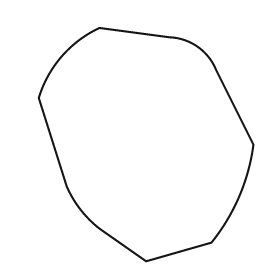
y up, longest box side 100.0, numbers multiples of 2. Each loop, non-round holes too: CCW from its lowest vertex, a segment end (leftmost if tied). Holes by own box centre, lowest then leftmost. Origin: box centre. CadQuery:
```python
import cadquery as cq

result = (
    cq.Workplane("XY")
    .moveTo(0.0, -50.0)
    .lineTo(28.0, -42.0)
    .threePointArc((40.0, -22.0), (46.0, 0.0))
    .lineTo(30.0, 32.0)
    .threePointArc((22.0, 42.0), (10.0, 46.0))
    .lineTo(-20.0, 50.0)
    .threePointArc((-36.0, 38.0), (-46.0, 20.0))
    .lineTo(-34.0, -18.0)
    .threePointArc((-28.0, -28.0), (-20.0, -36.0))
    .close()
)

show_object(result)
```